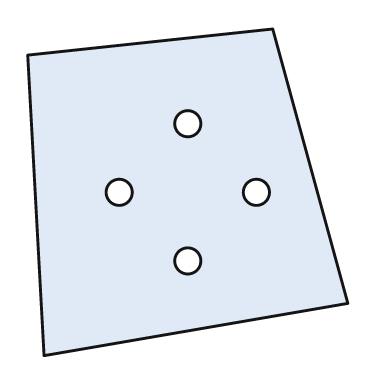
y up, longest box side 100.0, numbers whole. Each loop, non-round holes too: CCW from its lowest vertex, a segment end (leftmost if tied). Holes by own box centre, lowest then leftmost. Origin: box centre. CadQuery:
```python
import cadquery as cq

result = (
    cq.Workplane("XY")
    .moveTo(-44.0, -50.0)
    .lineTo(49.0, -34.0)
    .lineTo(26.0, 50.0)
    .lineTo(-49.0, 42.0)
    .close()
    .moveTo(0.0, -21.0)
    .circle(4.0)
    .moveTo(-21.0, 0.0)
    .circle(4.0)
    .moveTo(21.0, 0.0)
    .circle(4.0)
    .moveTo(0.0, 21.0)
    .circle(4.0)
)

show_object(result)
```